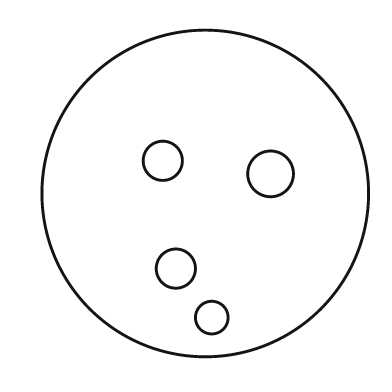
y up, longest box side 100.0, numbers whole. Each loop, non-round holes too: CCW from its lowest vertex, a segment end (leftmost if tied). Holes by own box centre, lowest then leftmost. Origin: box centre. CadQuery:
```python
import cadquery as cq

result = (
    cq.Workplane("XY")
    .moveTo(0.0, 0.0)
    .circle(50.0)
    .moveTo(2.0, -38.0)
    .circle(5.0)
    .moveTo(-9.0, -23.0)
    .circle(6.0)
    .moveTo(20.0, 6.0)
    .circle(7.0)
    .moveTo(-13.0, 10.0)
    .circle(6.0)
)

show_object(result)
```